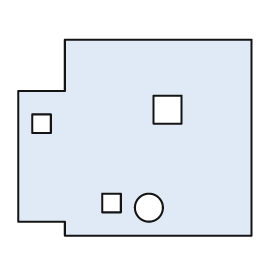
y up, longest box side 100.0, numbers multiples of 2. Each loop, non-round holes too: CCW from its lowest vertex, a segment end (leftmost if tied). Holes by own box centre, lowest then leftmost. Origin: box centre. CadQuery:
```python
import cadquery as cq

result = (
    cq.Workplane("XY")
    .moveTo(-30.0, -42.0)
    .lineTo(50.0, -42.0)
    .lineTo(50.0, 42.0)
    .lineTo(-30.0, 42.0)
    .lineTo(-30.0, 20.0)
    .lineTo(-50.0, 20.0)
    .lineTo(-50.0, -36.0)
    .lineTo(-30.0, -36.0)
    .close()
    .moveTo(6.0, -30.0)
    .circle(6.0)
    .moveTo(-14.0, -32.0)
    .lineTo(-6.0, -32.0)
    .lineTo(-6.0, -24.0)
    .lineTo(-14.0, -24.0)
    .close()
    .moveTo(-44.0, 2.0)
    .lineTo(-36.0, 2.0)
    .lineTo(-36.0, 10.0)
    .lineTo(-44.0, 10.0)
    .close()
    .moveTo(8.0, 6.0)
    .lineTo(20.0, 6.0)
    .lineTo(20.0, 18.0)
    .lineTo(8.0, 18.0)
    .close()
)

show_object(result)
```